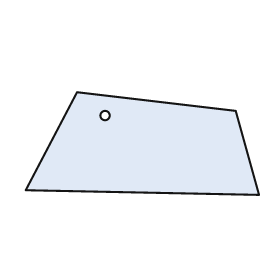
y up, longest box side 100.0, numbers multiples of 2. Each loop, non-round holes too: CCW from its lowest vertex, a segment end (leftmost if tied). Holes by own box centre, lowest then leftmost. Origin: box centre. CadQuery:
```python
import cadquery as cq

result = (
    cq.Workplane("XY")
    .moveTo(50.0, -22.0)
    .lineTo(40.0, 14.0)
    .lineTo(-28.0, 22.0)
    .lineTo(-50.0, -20.0)
    .close()
    .moveTo(-16.0, 12.0)
    .circle(2.0)
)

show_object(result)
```